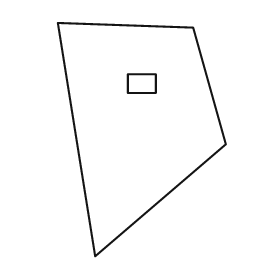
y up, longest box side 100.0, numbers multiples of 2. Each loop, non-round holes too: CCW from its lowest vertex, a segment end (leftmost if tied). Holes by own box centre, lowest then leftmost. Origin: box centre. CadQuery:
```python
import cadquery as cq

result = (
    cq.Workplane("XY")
    .moveTo(-20.0, -50.0)
    .lineTo(36.0, -2.0)
    .lineTo(22.0, 48.0)
    .lineTo(-36.0, 50.0)
    .close()
    .moveTo(-6.0, 20.0)
    .lineTo(6.0, 20.0)
    .lineTo(6.0, 28.0)
    .lineTo(-6.0, 28.0)
    .close()
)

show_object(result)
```